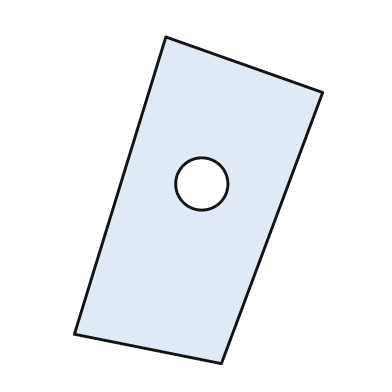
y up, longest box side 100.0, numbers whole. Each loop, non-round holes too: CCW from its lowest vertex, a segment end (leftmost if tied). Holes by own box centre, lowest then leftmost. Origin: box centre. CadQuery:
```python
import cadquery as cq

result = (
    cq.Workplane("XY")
    .moveTo(7.0, -50.0)
    .lineTo(38.0, 33.0)
    .lineTo(-10.0, 50.0)
    .lineTo(-38.0, -41.0)
    .close()
    .moveTo(1.0, 5.0)
    .circle(8.0)
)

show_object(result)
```